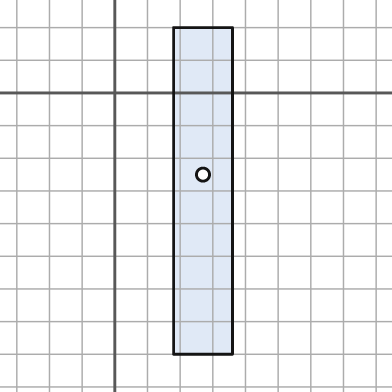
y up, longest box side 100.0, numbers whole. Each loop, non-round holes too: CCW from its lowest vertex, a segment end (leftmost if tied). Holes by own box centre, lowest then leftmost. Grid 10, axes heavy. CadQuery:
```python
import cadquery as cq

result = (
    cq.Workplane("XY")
    .moveTo(18.0, -80.0)
    .lineTo(36.0, -80.0)
    .lineTo(36.0, 20.0)
    .lineTo(18.0, 20.0)
    .close()
    .moveTo(27.0, -25.0)
    .circle(2.0)
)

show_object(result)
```